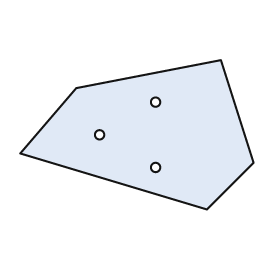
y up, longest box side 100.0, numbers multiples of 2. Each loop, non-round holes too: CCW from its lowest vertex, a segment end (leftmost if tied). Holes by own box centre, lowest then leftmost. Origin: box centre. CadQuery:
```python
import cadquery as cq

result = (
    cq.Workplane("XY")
    .moveTo(30.0, -32.0)
    .lineTo(50.0, -12.0)
    .lineTo(36.0, 32.0)
    .lineTo(-26.0, 20.0)
    .lineTo(-50.0, -8.0)
    .close()
    .moveTo(8.0, -14.0)
    .circle(2.0)
    .moveTo(-16.0, 0.0)
    .circle(2.0)
    .moveTo(8.0, 14.0)
    .circle(2.0)
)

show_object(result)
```